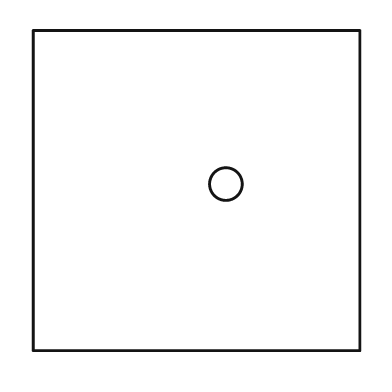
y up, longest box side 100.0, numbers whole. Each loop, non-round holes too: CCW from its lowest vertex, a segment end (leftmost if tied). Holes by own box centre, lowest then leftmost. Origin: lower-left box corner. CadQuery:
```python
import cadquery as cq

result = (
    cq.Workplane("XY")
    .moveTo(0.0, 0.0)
    .lineTo(100.0, 0.0)
    .lineTo(100.0, 98.0)
    .lineTo(0.0, 98.0)
    .close()
    .moveTo(59.0, 51.0)
    .circle(5.0)
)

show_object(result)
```